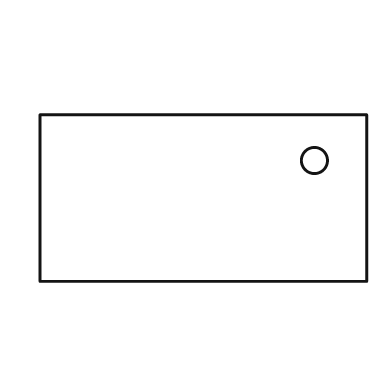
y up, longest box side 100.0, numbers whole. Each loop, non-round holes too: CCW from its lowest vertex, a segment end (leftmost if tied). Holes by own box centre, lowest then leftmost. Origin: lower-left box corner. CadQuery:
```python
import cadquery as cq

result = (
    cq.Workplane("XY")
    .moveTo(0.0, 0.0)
    .lineTo(100.0, 0.0)
    .lineTo(100.0, 51.0)
    .lineTo(0.0, 51.0)
    .close()
    .moveTo(84.0, 37.0)
    .circle(4.0)
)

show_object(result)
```